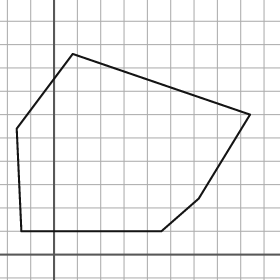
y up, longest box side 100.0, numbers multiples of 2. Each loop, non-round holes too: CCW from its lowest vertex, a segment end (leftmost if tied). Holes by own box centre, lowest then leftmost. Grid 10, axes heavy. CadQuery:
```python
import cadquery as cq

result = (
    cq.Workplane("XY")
    .moveTo(-14.0, 10.0)
    .lineTo(46.0, 10.0)
    .lineTo(62.0, 24.0)
    .lineTo(84.0, 60.0)
    .lineTo(8.0, 86.0)
    .lineTo(-16.0, 54.0)
    .close()
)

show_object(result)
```